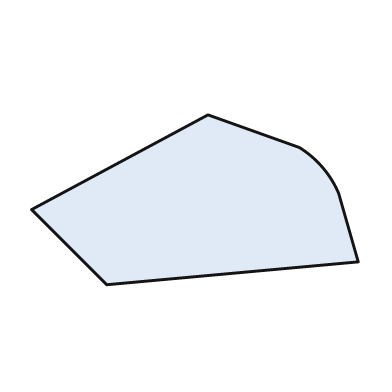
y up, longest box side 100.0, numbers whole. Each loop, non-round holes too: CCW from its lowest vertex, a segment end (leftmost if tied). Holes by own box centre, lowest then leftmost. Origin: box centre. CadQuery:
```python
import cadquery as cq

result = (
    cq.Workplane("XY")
    .moveTo(-27.0, -26.0)
    .lineTo(50.0, -19.0)
    .lineTo(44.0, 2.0)
    .threePointArc((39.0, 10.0), (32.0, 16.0))
    .lineTo(4.0, 26.0)
    .lineTo(-50.0, -3.0)
    .close()
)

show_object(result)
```